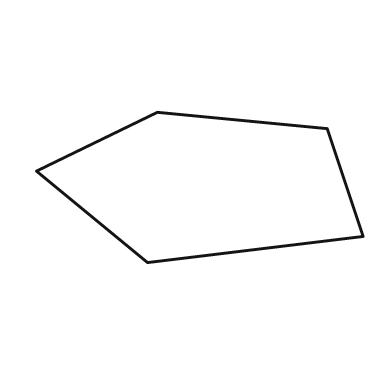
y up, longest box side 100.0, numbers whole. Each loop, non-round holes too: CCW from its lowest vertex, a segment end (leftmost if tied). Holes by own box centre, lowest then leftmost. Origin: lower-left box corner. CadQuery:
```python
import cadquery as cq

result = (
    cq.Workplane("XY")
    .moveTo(34.0, 0.0)
    .lineTo(100.0, 8.0)
    .lineTo(89.0, 41.0)
    .lineTo(37.0, 46.0)
    .lineTo(0.0, 28.0)
    .close()
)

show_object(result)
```